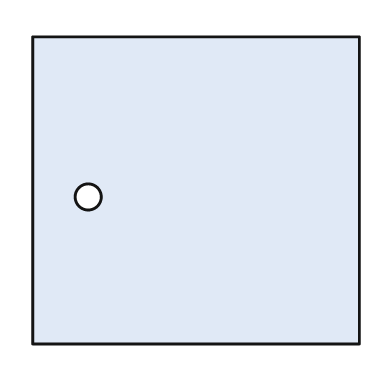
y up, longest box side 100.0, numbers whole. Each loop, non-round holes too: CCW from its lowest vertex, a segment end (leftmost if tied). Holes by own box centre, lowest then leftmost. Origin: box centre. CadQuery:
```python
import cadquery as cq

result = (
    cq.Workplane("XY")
    .moveTo(-50.0, -47.0)
    .lineTo(50.0, -47.0)
    .lineTo(50.0, 47.0)
    .lineTo(-50.0, 47.0)
    .close()
    .moveTo(-33.0, -2.0)
    .circle(4.0)
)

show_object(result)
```